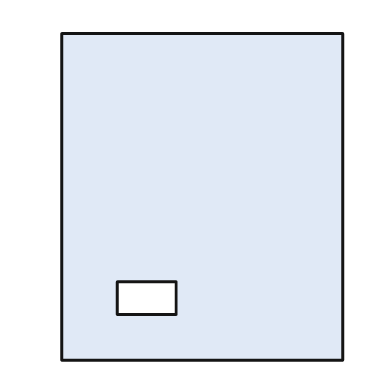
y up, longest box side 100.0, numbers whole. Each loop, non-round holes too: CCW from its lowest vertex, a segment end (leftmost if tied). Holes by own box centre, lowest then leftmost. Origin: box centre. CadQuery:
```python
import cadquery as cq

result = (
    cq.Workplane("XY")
    .moveTo(-43.0, -50.0)
    .lineTo(43.0, -50.0)
    .lineTo(43.0, 50.0)
    .lineTo(-43.0, 50.0)
    .close()
    .moveTo(-26.0, -36.0)
    .lineTo(-8.0, -36.0)
    .lineTo(-8.0, -26.0)
    .lineTo(-26.0, -26.0)
    .close()
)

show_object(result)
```